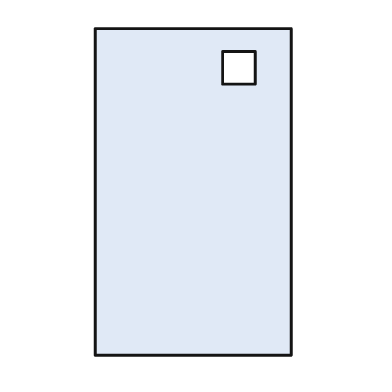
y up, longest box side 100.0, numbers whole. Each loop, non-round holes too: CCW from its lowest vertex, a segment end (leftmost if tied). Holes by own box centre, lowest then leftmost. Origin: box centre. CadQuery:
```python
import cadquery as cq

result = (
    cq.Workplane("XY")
    .moveTo(-30.0, -50.0)
    .lineTo(30.0, -50.0)
    .lineTo(30.0, 50.0)
    .lineTo(-30.0, 50.0)
    .close()
    .moveTo(9.0, 33.0)
    .lineTo(19.0, 33.0)
    .lineTo(19.0, 43.0)
    .lineTo(9.0, 43.0)
    .close()
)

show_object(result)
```